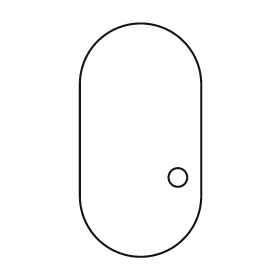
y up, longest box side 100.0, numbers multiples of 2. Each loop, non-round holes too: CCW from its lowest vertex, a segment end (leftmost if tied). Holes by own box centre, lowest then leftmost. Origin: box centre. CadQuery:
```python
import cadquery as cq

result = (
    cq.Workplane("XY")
    .moveTo(-26.0, -24.0)
    .threePointArc((0.0, -50.0), (26.0, -24.0))
    .lineTo(26.0, 24.0)
    .threePointArc((0.0, 50.0), (-26.0, 24.0))
    .close()
    .moveTo(16.0, -16.0)
    .circle(4.0)
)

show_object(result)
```